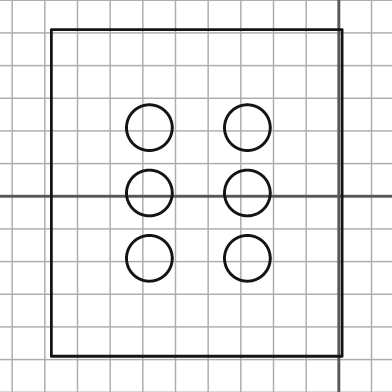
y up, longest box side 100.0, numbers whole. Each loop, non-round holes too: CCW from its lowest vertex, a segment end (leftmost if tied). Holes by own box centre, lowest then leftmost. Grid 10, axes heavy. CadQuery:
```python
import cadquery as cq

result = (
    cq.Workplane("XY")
    .moveTo(-88.0, -49.0)
    .lineTo(1.0, -49.0)
    .lineTo(1.0, 51.0)
    .lineTo(-88.0, 51.0)
    .close()
    .moveTo(-58.0, -19.0)
    .circle(7.0)
    .moveTo(-28.0, -19.0)
    .circle(7.0)
    .moveTo(-58.0, 1.0)
    .circle(7.0)
    .moveTo(-28.0, 1.0)
    .circle(7.0)
    .moveTo(-58.0, 21.0)
    .circle(7.0)
    .moveTo(-28.0, 21.0)
    .circle(7.0)
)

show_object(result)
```